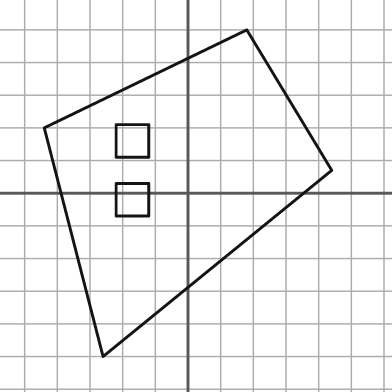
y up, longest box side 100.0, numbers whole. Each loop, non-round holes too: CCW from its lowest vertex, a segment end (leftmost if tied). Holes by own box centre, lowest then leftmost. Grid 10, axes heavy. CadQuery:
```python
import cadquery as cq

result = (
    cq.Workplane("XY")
    .moveTo(-26.0, -50.0)
    .lineTo(44.0, 7.0)
    .lineTo(18.0, 50.0)
    .lineTo(-44.0, 20.0)
    .close()
    .moveTo(-22.0, -7.0)
    .lineTo(-12.0, -7.0)
    .lineTo(-12.0, 3.0)
    .lineTo(-22.0, 3.0)
    .close()
    .moveTo(-22.0, 11.0)
    .lineTo(-12.0, 11.0)
    .lineTo(-12.0, 21.0)
    .lineTo(-22.0, 21.0)
    .close()
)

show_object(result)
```